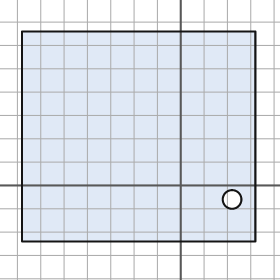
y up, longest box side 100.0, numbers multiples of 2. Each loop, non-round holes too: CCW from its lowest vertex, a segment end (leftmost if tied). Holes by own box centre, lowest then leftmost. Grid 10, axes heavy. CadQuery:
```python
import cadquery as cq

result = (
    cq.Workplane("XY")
    .moveTo(-68.0, -24.0)
    .lineTo(32.0, -24.0)
    .lineTo(32.0, 66.0)
    .lineTo(-68.0, 66.0)
    .close()
    .moveTo(22.0, -6.0)
    .circle(4.0)
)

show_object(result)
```